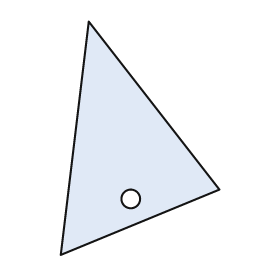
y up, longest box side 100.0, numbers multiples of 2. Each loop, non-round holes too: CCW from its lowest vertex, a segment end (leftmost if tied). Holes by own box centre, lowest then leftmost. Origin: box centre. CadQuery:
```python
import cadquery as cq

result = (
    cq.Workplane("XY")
    .moveTo(-34.0, -50.0)
    .lineTo(34.0, -22.0)
    .lineTo(-22.0, 50.0)
    .close()
    .moveTo(-4.0, -26.0)
    .circle(4.0)
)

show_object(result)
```